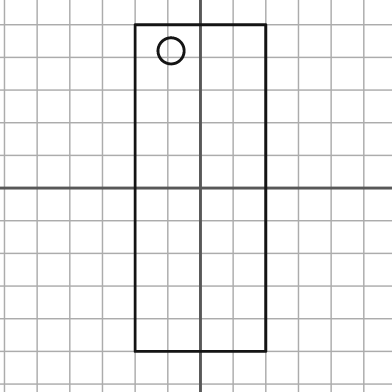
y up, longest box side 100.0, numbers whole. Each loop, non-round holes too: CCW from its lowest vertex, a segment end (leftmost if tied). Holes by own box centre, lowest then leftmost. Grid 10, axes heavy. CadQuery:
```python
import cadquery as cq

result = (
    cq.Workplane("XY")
    .moveTo(-20.0, -50.0)
    .lineTo(20.0, -50.0)
    .lineTo(20.0, 50.0)
    .lineTo(-20.0, 50.0)
    .close()
    .moveTo(-9.0, 42.0)
    .circle(4.0)
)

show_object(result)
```